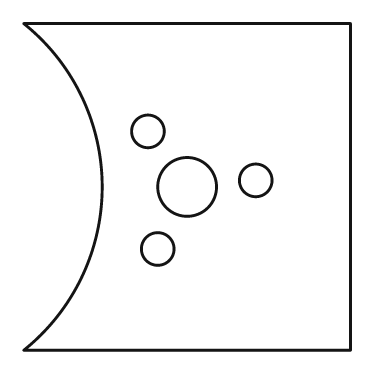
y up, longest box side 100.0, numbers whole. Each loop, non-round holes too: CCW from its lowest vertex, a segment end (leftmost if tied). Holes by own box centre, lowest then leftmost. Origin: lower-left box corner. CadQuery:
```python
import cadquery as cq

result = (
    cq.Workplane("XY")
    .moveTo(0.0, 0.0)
    .lineTo(100.0, 0.0)
    .lineTo(100.0, 100.0)
    .lineTo(0.0, 100.0)
    .threePointArc((24.0, 50.0), (0.0, 0.0))
    .close()
    .moveTo(41.0, 31.0)
    .circle(5.0)
    .moveTo(50.0, 50.0)
    .circle(9.0)
    .moveTo(71.0, 52.0)
    .circle(5.0)
    .moveTo(38.0, 67.0)
    .circle(5.0)
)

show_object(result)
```